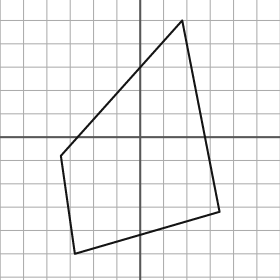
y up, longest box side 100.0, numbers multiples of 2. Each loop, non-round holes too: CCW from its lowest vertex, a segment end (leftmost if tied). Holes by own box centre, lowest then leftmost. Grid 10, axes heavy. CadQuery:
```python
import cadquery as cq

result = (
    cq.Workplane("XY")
    .moveTo(-28.0, -50.0)
    .lineTo(34.0, -32.0)
    .lineTo(18.0, 50.0)
    .lineTo(-34.0, -8.0)
    .close()
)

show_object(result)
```